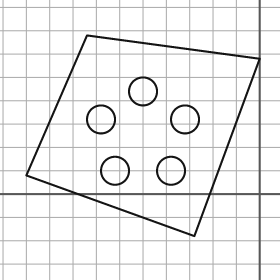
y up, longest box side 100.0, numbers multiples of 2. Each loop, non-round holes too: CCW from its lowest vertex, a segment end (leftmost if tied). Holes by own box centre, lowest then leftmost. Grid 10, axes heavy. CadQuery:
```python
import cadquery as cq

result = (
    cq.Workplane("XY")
    .moveTo(-28.0, -18.0)
    .lineTo(0.0, 58.0)
    .lineTo(-74.0, 68.0)
    .lineTo(-100.0, 8.0)
    .close()
    .moveTo(-62.0, 10.0)
    .circle(6.0)
    .moveTo(-38.0, 10.0)
    .circle(6.0)
    .moveTo(-68.0, 32.0)
    .circle(6.0)
    .moveTo(-32.0, 32.0)
    .circle(6.0)
    .moveTo(-50.0, 44.0)
    .circle(6.0)
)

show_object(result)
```